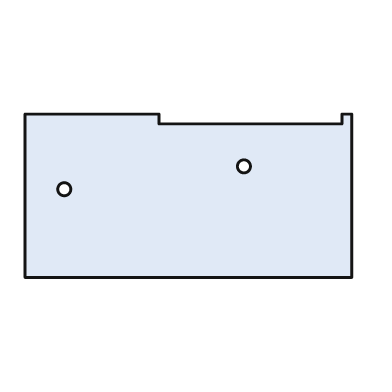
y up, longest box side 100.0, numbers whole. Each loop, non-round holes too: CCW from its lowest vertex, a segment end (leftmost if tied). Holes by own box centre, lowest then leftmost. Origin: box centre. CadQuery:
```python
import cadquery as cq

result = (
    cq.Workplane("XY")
    .moveTo(-50.0, -25.0)
    .lineTo(50.0, -25.0)
    .lineTo(50.0, 25.0)
    .lineTo(47.0, 25.0)
    .lineTo(47.0, 22.0)
    .lineTo(-9.0, 22.0)
    .lineTo(-9.0, 25.0)
    .lineTo(-50.0, 25.0)
    .close()
    .moveTo(-38.0, 2.0)
    .circle(2.0)
    .moveTo(17.0, 9.0)
    .circle(2.0)
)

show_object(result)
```